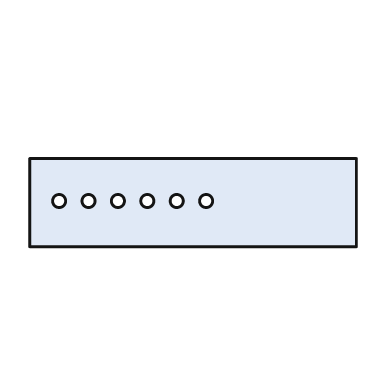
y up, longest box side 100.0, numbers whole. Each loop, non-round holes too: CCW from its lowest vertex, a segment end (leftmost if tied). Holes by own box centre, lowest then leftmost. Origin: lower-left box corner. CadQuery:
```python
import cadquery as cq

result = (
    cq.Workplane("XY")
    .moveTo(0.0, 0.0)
    .lineTo(100.0, 0.0)
    .lineTo(100.0, 27.0)
    .lineTo(0.0, 27.0)
    .close()
    .moveTo(9.0, 14.0)
    .circle(2.0)
    .moveTo(18.0, 14.0)
    .circle(2.0)
    .moveTo(27.0, 14.0)
    .circle(2.0)
    .moveTo(36.0, 14.0)
    .circle(2.0)
    .moveTo(45.0, 14.0)
    .circle(2.0)
    .moveTo(54.0, 14.0)
    .circle(2.0)
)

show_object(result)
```